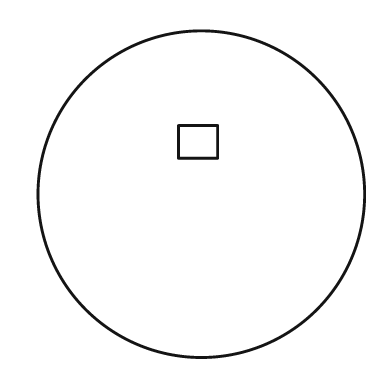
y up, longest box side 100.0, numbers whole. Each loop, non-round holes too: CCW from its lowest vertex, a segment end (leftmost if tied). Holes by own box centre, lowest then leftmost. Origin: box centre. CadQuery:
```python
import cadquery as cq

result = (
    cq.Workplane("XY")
    .moveTo(0.0, 0.0)
    .circle(50.0)
    .moveTo(-7.0, 11.0)
    .lineTo(5.0, 11.0)
    .lineTo(5.0, 21.0)
    .lineTo(-7.0, 21.0)
    .close()
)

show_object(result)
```